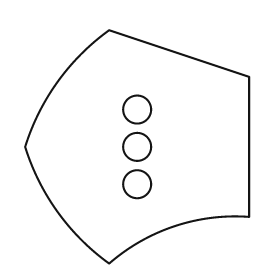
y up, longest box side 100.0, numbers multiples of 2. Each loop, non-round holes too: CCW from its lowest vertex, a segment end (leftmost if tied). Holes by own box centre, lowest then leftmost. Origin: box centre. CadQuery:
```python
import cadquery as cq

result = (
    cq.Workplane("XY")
    .moveTo(-12.0, -50.0)
    .threePointArc((16.0, -34.0), (48.0, -30.0))
    .lineTo(48.0, 30.0)
    .lineTo(-12.0, 50.0)
    .threePointArc((-34.0, 28.0), (-48.0, 0.0))
    .threePointArc((-34.0, -28.0), (-12.0, -50.0))
    .close()
    .moveTo(0.0, -16.0)
    .circle(6.0)
    .moveTo(0.0, 0.0)
    .circle(6.0)
    .moveTo(0.0, 16.0)
    .circle(6.0)
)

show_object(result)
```